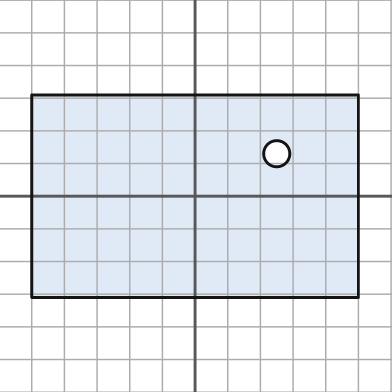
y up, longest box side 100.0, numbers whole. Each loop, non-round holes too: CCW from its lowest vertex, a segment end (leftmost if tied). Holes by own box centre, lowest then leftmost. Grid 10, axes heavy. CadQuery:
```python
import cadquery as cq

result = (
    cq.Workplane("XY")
    .moveTo(-50.0, -31.0)
    .lineTo(50.0, -31.0)
    .lineTo(50.0, 31.0)
    .lineTo(-50.0, 31.0)
    .close()
    .moveTo(25.0, 13.0)
    .circle(4.0)
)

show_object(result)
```